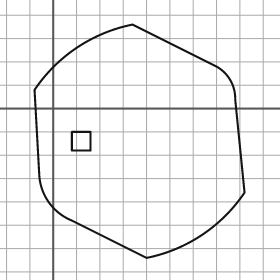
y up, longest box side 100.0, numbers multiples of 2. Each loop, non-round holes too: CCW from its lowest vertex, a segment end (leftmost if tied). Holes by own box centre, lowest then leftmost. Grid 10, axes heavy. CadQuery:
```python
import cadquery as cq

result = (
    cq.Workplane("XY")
    .moveTo(40.0, -64.0)
    .threePointArc((64.0, -54.0), (82.0, -36.0))
    .lineTo(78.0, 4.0)
    .threePointArc((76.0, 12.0), (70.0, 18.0))
    .lineTo(34.0, 36.0)
    .threePointArc((10.0, 26.0), (-8.0, 8.0))
    .lineTo(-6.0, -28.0)
    .threePointArc((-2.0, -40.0), (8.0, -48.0))
    .close()
    .moveTo(8.0, -18.0)
    .lineTo(16.0, -18.0)
    .lineTo(16.0, -10.0)
    .lineTo(8.0, -10.0)
    .close()
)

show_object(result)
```